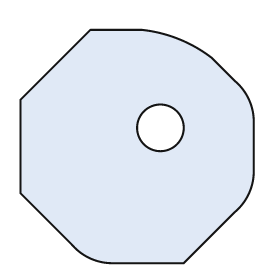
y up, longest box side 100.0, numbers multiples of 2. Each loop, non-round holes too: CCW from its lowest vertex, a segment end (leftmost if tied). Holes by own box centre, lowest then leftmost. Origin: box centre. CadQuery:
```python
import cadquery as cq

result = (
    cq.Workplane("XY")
    .moveTo(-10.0, -50.0)
    .lineTo(20.0, -50.0)
    .lineTo(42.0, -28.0)
    .threePointArc((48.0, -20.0), (50.0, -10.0))
    .lineTo(50.0, 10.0)
    .threePointArc((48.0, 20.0), (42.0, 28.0))
    .lineTo(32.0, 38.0)
    .threePointArc((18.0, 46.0), (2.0, 50.0))
    .lineTo(-20.0, 50.0)
    .lineTo(-50.0, 20.0)
    .lineTo(-50.0, -20.0)
    .lineTo(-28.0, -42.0)
    .threePointArc((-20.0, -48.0), (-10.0, -50.0))
    .close()
    .moveTo(10.0, 8.0)
    .circle(10.0)
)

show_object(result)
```